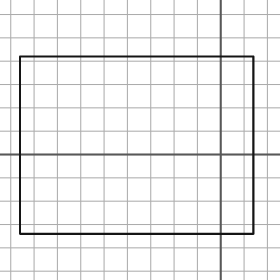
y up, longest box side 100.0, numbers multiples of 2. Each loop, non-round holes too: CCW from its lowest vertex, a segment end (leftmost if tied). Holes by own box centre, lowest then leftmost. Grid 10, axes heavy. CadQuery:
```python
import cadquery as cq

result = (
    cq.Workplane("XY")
    .moveTo(-86.0, -34.0)
    .lineTo(14.0, -34.0)
    .lineTo(14.0, 42.0)
    .lineTo(-86.0, 42.0)
    .close()
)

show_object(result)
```